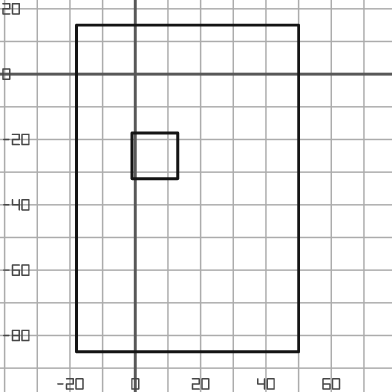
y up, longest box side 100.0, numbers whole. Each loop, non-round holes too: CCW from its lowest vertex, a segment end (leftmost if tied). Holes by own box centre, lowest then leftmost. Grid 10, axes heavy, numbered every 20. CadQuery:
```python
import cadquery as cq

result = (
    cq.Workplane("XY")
    .moveTo(-18.0, -85.0)
    .lineTo(50.0, -85.0)
    .lineTo(50.0, 15.0)
    .lineTo(-18.0, 15.0)
    .close()
    .moveTo(-1.0, -32.0)
    .lineTo(13.0, -32.0)
    .lineTo(13.0, -18.0)
    .lineTo(-1.0, -18.0)
    .close()
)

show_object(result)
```